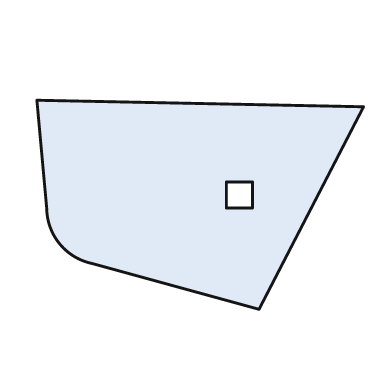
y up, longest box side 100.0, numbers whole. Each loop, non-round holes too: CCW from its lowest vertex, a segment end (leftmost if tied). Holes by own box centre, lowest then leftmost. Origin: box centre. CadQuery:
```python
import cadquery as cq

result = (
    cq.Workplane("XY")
    .moveTo(18.0, -32.0)
    .lineTo(50.0, 30.0)
    .lineTo(-50.0, 32.0)
    .lineTo(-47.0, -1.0)
    .threePointArc((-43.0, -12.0), (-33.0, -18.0))
    .close()
    .moveTo(8.0, -1.0)
    .lineTo(16.0, -1.0)
    .lineTo(16.0, 7.0)
    .lineTo(8.0, 7.0)
    .close()
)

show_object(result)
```